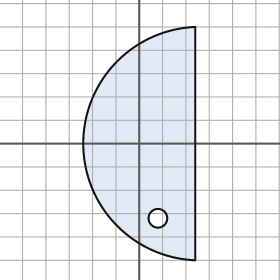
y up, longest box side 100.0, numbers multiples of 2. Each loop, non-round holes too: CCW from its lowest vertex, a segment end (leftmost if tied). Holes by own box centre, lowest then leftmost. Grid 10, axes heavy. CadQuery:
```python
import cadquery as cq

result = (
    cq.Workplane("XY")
    .moveTo(24.0, -50.0)
    .lineTo(24.0, 50.0)
    .threePointArc((-24.0, 0.0), (24.0, -50.0))
    .close()
    .moveTo(8.0, -32.0)
    .circle(4.0)
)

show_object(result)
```